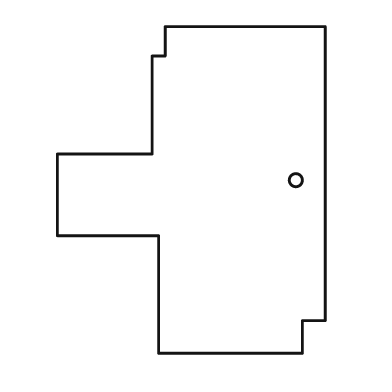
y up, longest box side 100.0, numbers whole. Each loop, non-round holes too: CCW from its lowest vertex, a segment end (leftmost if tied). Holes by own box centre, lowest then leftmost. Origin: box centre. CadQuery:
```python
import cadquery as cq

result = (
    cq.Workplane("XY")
    .moveTo(-10.0, -50.0)
    .lineTo(34.0, -50.0)
    .lineTo(34.0, -40.0)
    .lineTo(41.0, -40.0)
    .lineTo(41.0, 50.0)
    .lineTo(-8.0, 50.0)
    .lineTo(-8.0, 41.0)
    .lineTo(-12.0, 41.0)
    .lineTo(-12.0, 11.0)
    .lineTo(-41.0, 11.0)
    .lineTo(-41.0, -14.0)
    .lineTo(-10.0, -14.0)
    .close()
    .moveTo(32.0, 3.0)
    .circle(2.0)
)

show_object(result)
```